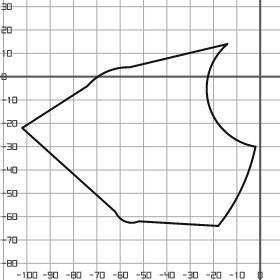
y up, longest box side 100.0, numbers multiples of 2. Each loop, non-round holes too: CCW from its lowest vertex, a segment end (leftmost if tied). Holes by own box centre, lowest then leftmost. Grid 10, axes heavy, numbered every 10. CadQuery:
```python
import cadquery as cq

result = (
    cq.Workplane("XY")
    .moveTo(-18.0, -64.0)
    .threePointArc((-8.0, -48.0), (-2.0, -30.0))
    .threePointArc((-22.0, -12.0), (-14.0, 14.0))
    .lineTo(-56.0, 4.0)
    .threePointArc((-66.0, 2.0), (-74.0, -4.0))
    .lineTo(-102.0, -22.0)
    .lineTo(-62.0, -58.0)
    .threePointArc((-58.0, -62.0), (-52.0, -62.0))
    .close()
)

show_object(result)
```